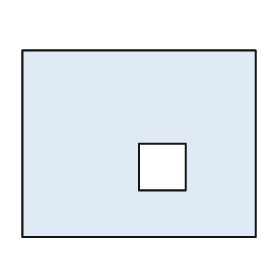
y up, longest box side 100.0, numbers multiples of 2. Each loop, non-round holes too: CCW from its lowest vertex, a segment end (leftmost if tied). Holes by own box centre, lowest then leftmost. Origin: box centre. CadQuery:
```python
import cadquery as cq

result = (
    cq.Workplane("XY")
    .moveTo(-50.0, -40.0)
    .lineTo(50.0, -40.0)
    .lineTo(50.0, 40.0)
    .lineTo(-50.0, 40.0)
    .close()
    .moveTo(0.0, -20.0)
    .lineTo(20.0, -20.0)
    .lineTo(20.0, 0.0)
    .lineTo(0.0, 0.0)
    .close()
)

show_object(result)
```